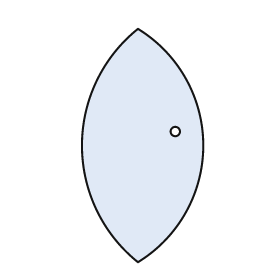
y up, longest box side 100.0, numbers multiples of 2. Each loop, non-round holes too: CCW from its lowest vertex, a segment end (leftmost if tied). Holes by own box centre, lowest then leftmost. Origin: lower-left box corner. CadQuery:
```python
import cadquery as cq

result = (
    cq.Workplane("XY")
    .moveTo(24.0, 0.0)
    .threePointArc((52.0, 50.0), (24.0, 100.0))
    .threePointArc((0.0, 50.0), (24.0, 0.0))
    .close()
    .moveTo(40.0, 56.0)
    .circle(2.0)
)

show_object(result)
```